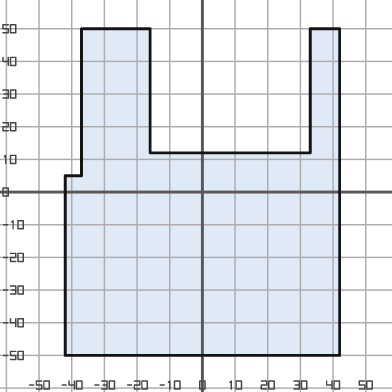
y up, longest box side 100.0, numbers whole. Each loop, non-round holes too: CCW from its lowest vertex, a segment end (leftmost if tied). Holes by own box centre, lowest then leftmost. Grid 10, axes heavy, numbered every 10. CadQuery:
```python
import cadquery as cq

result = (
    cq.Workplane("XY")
    .moveTo(-42.0, -50.0)
    .lineTo(42.0, -50.0)
    .lineTo(42.0, 50.0)
    .lineTo(33.0, 50.0)
    .lineTo(33.0, 12.0)
    .lineTo(-16.0, 12.0)
    .lineTo(-16.0, 50.0)
    .lineTo(-37.0, 50.0)
    .lineTo(-37.0, 5.0)
    .lineTo(-42.0, 5.0)
    .close()
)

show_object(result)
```